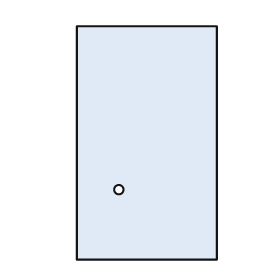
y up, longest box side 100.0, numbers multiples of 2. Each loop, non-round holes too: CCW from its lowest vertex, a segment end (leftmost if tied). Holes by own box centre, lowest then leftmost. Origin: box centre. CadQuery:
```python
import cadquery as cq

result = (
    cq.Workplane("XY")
    .moveTo(-30.0, -50.0)
    .lineTo(30.0, -50.0)
    .lineTo(30.0, 50.0)
    .lineTo(-30.0, 50.0)
    .close()
    .moveTo(-12.0, -20.0)
    .circle(2.0)
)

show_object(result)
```